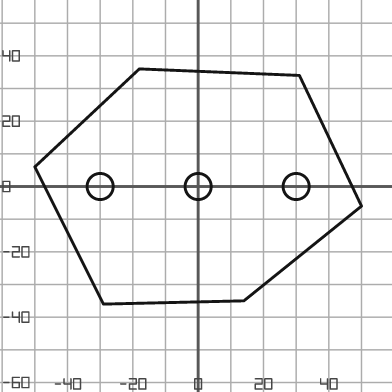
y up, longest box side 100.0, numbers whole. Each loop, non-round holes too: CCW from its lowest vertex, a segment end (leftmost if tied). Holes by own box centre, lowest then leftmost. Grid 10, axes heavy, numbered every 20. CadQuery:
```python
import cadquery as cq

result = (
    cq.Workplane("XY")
    .moveTo(-29.0, -36.0)
    .lineTo(14.0, -35.0)
    .lineTo(50.0, -6.0)
    .lineTo(31.0, 34.0)
    .lineTo(-18.0, 36.0)
    .lineTo(-50.0, 6.0)
    .close()
    .moveTo(-30.0, 0.0)
    .circle(4.0)
    .moveTo(0.0, 0.0)
    .circle(4.0)
    .moveTo(30.0, 0.0)
    .circle(4.0)
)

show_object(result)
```